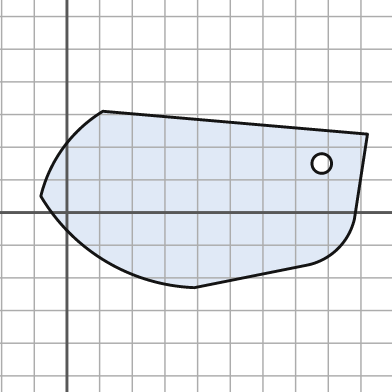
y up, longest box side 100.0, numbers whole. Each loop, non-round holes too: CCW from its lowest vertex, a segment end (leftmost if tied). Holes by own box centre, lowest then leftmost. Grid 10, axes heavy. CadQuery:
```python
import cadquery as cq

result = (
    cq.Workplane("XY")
    .moveTo(39.0, -23.0)
    .lineTo(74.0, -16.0)
    .threePointArc((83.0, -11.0), (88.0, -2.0))
    .lineTo(92.0, 24.0)
    .lineTo(11.0, 31.0)
    .threePointArc((-1.0, 20.0), (-8.0, 5.0))
    .threePointArc((12.0, -15.0), (39.0, -23.0))
    .close()
    .moveTo(78.0, 15.0)
    .circle(3.0)
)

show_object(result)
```